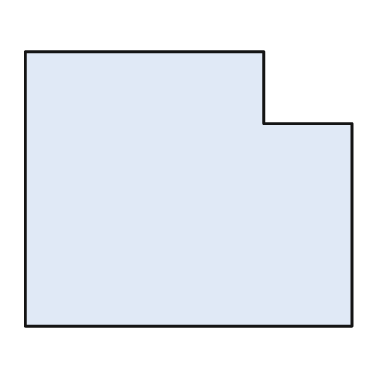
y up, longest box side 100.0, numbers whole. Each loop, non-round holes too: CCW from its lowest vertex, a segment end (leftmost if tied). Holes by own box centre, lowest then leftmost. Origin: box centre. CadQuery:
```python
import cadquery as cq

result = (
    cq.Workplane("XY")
    .moveTo(-50.0, -42.0)
    .lineTo(50.0, -42.0)
    .lineTo(50.0, 20.0)
    .lineTo(23.0, 20.0)
    .lineTo(23.0, 42.0)
    .lineTo(-50.0, 42.0)
    .close()
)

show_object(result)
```